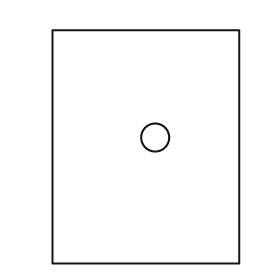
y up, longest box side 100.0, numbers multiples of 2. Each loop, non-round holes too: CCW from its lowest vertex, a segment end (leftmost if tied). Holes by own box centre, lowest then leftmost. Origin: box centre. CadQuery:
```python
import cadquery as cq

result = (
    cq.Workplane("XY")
    .moveTo(-40.0, -50.0)
    .lineTo(40.0, -50.0)
    .lineTo(40.0, 50.0)
    .lineTo(-40.0, 50.0)
    .close()
    .moveTo(4.0, 4.0)
    .circle(6.0)
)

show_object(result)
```